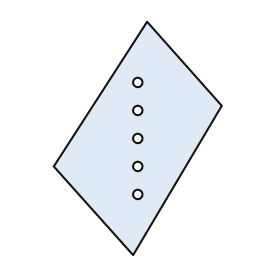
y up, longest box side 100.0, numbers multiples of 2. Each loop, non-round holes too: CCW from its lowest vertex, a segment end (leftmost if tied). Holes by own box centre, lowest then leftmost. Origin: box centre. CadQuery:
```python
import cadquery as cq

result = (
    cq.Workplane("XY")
    .moveTo(-2.0, -50.0)
    .lineTo(36.0, 14.0)
    .lineTo(4.0, 50.0)
    .lineTo(-36.0, -12.0)
    .close()
    .moveTo(0.0, -24.0)
    .circle(2.0)
    .moveTo(0.0, -12.0)
    .circle(2.0)
    .moveTo(0.0, 0.0)
    .circle(2.0)
    .moveTo(0.0, 12.0)
    .circle(2.0)
    .moveTo(0.0, 24.0)
    .circle(2.0)
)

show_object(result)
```